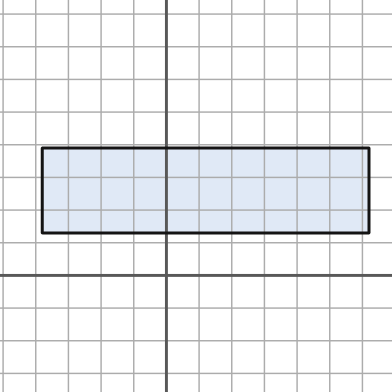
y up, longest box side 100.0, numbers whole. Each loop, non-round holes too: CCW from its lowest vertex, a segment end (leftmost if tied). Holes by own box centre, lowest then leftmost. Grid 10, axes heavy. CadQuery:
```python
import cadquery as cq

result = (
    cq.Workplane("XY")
    .moveTo(-38.0, 13.0)
    .lineTo(62.0, 13.0)
    .lineTo(62.0, 39.0)
    .lineTo(-38.0, 39.0)
    .close()
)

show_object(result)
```